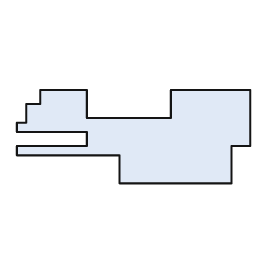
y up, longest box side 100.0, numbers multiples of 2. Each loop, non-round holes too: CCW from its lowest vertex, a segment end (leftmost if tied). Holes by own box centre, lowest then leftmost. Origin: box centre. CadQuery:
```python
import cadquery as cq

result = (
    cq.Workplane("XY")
    .moveTo(-6.0, -20.0)
    .lineTo(42.0, -20.0)
    .lineTo(42.0, -4.0)
    .lineTo(50.0, -4.0)
    .lineTo(50.0, 20.0)
    .lineTo(16.0, 20.0)
    .lineTo(16.0, 8.0)
    .lineTo(-20.0, 8.0)
    .lineTo(-20.0, 20.0)
    .lineTo(-40.0, 20.0)
    .lineTo(-40.0, 14.0)
    .lineTo(-46.0, 14.0)
    .lineTo(-46.0, 6.0)
    .lineTo(-50.0, 6.0)
    .lineTo(-50.0, 2.0)
    .lineTo(-20.0, 2.0)
    .lineTo(-20.0, -4.0)
    .lineTo(-50.0, -4.0)
    .lineTo(-50.0, -8.0)
    .lineTo(-6.0, -8.0)
    .close()
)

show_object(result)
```